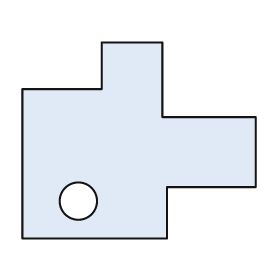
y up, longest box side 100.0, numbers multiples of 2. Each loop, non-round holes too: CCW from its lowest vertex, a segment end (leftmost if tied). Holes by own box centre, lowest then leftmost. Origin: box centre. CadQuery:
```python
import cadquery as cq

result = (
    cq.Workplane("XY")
    .moveTo(-50.0, -42.0)
    .lineTo(12.0, -42.0)
    .lineTo(12.0, -20.0)
    .lineTo(50.0, -20.0)
    .lineTo(50.0, 10.0)
    .lineTo(10.0, 10.0)
    .lineTo(10.0, 42.0)
    .lineTo(-16.0, 42.0)
    .lineTo(-16.0, 22.0)
    .lineTo(-50.0, 22.0)
    .close()
    .moveTo(-26.0, -26.0)
    .circle(8.0)
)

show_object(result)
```